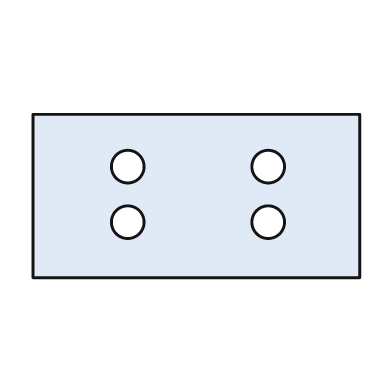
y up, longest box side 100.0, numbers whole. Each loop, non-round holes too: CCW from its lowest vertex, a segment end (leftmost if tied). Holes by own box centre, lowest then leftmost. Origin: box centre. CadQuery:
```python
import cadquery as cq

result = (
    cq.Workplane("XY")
    .moveTo(-50.0, -25.0)
    .lineTo(50.0, -25.0)
    .lineTo(50.0, 25.0)
    .lineTo(-50.0, 25.0)
    .close()
    .moveTo(-21.0, -8.0)
    .circle(5.0)
    .moveTo(22.0, -8.0)
    .circle(5.0)
    .moveTo(-21.0, 9.0)
    .circle(5.0)
    .moveTo(22.0, 9.0)
    .circle(5.0)
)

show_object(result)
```